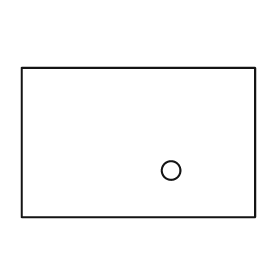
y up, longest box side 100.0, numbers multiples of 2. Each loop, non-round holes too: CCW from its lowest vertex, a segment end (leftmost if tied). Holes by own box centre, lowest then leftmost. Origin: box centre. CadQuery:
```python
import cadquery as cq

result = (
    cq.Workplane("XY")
    .moveTo(-50.0, -32.0)
    .lineTo(50.0, -32.0)
    .lineTo(50.0, 32.0)
    .lineTo(-50.0, 32.0)
    .close()
    .moveTo(14.0, -12.0)
    .circle(4.0)
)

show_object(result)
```